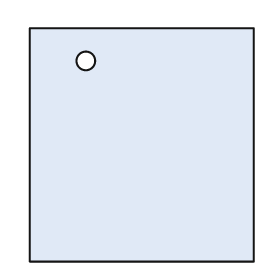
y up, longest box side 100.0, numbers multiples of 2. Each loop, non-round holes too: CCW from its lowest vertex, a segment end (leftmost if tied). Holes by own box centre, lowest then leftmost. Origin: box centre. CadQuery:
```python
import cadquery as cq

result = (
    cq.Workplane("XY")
    .moveTo(-48.0, -50.0)
    .lineTo(48.0, -50.0)
    .lineTo(48.0, 50.0)
    .lineTo(-48.0, 50.0)
    .close()
    .moveTo(-24.0, 36.0)
    .circle(4.0)
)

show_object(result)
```